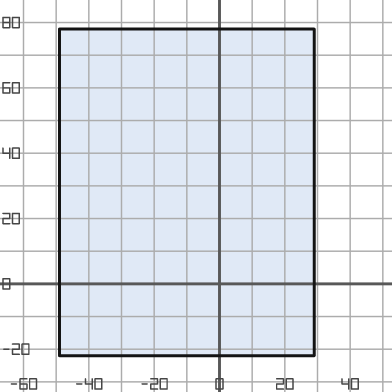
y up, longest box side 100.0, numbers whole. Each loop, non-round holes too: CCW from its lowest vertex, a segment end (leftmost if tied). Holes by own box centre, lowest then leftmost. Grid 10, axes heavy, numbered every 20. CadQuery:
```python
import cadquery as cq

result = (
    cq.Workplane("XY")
    .moveTo(-49.0, -22.0)
    .lineTo(29.0, -22.0)
    .lineTo(29.0, 78.0)
    .lineTo(-49.0, 78.0)
    .close()
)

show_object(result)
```